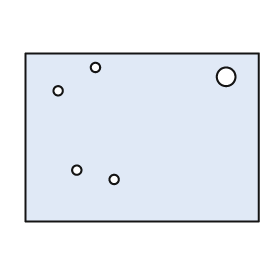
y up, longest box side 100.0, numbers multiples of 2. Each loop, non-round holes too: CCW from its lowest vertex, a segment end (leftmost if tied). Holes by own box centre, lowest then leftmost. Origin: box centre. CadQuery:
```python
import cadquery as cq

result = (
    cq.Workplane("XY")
    .moveTo(-50.0, -36.0)
    .lineTo(50.0, -36.0)
    .lineTo(50.0, 36.0)
    .lineTo(-50.0, 36.0)
    .close()
    .moveTo(-12.0, -18.0)
    .circle(2.0)
    .moveTo(-28.0, -14.0)
    .circle(2.0)
    .moveTo(-36.0, 20.0)
    .circle(2.0)
    .moveTo(36.0, 26.0)
    .circle(4.0)
    .moveTo(-20.0, 30.0)
    .circle(2.0)
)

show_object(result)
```